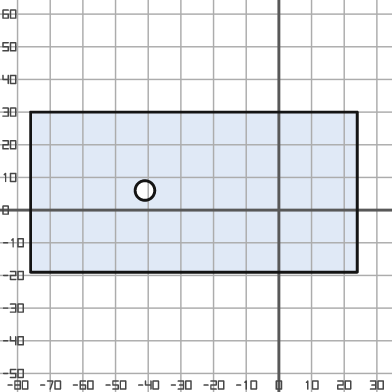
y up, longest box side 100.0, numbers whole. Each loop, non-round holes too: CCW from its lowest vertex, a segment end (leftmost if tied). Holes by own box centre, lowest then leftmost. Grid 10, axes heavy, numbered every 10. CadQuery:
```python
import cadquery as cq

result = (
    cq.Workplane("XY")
    .moveTo(-76.0, -19.0)
    .lineTo(24.0, -19.0)
    .lineTo(24.0, 30.0)
    .lineTo(-76.0, 30.0)
    .close()
    .moveTo(-41.0, 6.0)
    .circle(3.0)
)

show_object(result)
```